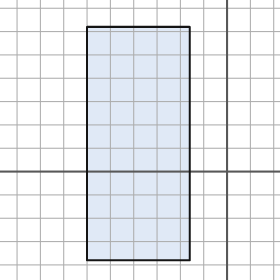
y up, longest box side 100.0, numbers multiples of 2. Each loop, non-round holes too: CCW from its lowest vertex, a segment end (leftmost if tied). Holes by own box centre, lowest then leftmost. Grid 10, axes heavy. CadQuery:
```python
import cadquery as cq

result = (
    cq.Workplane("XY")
    .moveTo(-60.0, -38.0)
    .lineTo(-16.0, -38.0)
    .lineTo(-16.0, 62.0)
    .lineTo(-60.0, 62.0)
    .close()
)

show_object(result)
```